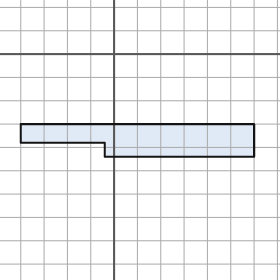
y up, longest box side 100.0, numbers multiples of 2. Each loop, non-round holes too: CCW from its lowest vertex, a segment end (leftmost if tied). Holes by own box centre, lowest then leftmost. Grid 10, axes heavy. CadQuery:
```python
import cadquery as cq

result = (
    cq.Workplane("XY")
    .moveTo(-4.0, -44.0)
    .lineTo(60.0, -44.0)
    .lineTo(60.0, -30.0)
    .lineTo(-40.0, -30.0)
    .lineTo(-40.0, -38.0)
    .lineTo(-4.0, -38.0)
    .close()
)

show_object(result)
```